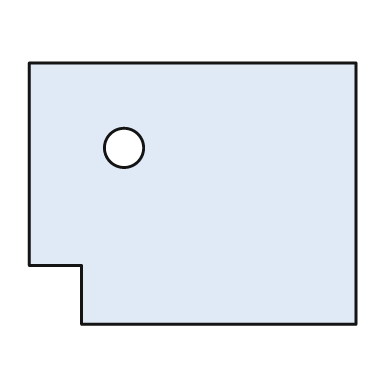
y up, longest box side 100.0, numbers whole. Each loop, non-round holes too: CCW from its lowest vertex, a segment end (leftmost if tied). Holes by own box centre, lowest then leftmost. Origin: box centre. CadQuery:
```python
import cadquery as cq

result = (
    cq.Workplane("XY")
    .moveTo(-34.0, -40.0)
    .lineTo(50.0, -40.0)
    .lineTo(50.0, 40.0)
    .lineTo(-50.0, 40.0)
    .lineTo(-50.0, -22.0)
    .lineTo(-34.0, -22.0)
    .close()
    .moveTo(-21.0, 14.0)
    .circle(6.0)
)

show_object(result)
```